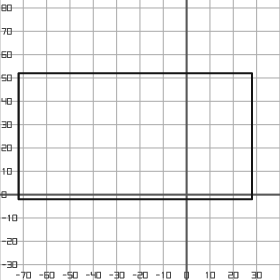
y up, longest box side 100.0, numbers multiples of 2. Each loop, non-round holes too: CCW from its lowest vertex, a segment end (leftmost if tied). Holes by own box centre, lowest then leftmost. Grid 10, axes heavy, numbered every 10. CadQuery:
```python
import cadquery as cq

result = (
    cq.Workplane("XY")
    .moveTo(-72.0, -2.0)
    .lineTo(28.0, -2.0)
    .lineTo(28.0, 52.0)
    .lineTo(-72.0, 52.0)
    .close()
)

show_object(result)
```